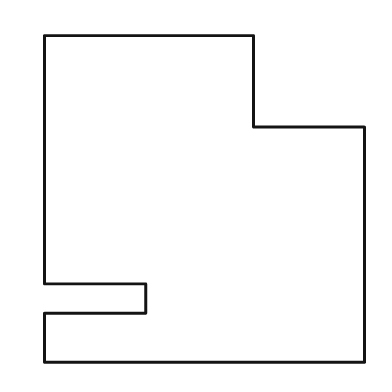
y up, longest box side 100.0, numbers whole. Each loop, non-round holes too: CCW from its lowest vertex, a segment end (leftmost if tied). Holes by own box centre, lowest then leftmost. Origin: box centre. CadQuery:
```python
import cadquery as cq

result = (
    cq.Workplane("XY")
    .moveTo(-49.0, -50.0)
    .lineTo(49.0, -50.0)
    .lineTo(49.0, 22.0)
    .lineTo(15.0, 22.0)
    .lineTo(15.0, 50.0)
    .lineTo(-49.0, 50.0)
    .lineTo(-49.0, -26.0)
    .lineTo(-18.0, -26.0)
    .lineTo(-18.0, -35.0)
    .lineTo(-49.0, -35.0)
    .close()
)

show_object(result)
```